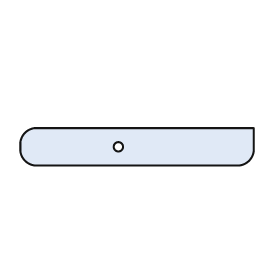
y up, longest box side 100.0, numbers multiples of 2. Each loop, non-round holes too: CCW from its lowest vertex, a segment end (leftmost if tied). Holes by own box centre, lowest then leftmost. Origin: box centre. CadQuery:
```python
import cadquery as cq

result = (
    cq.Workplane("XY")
    .moveTo(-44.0, -8.0)
    .lineTo(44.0, -8.0)
    .threePointArc((48.0, -6.0), (50.0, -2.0))
    .lineTo(50.0, 8.0)
    .lineTo(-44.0, 8.0)
    .threePointArc((-48.0, 6.0), (-50.0, 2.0))
    .lineTo(-50.0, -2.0)
    .threePointArc((-48.0, -6.0), (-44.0, -8.0))
    .close()
    .moveTo(-8.0, 0.0)
    .circle(2.0)
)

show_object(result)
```